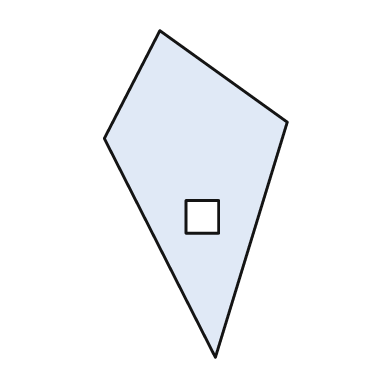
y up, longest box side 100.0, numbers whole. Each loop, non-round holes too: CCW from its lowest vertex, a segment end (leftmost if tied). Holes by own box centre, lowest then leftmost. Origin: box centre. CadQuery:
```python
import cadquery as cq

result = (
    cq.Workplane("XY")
    .moveTo(6.0, -50.0)
    .lineTo(28.0, 22.0)
    .lineTo(-11.0, 50.0)
    .lineTo(-28.0, 17.0)
    .close()
    .moveTo(-3.0, -12.0)
    .lineTo(7.0, -12.0)
    .lineTo(7.0, -2.0)
    .lineTo(-3.0, -2.0)
    .close()
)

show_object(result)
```